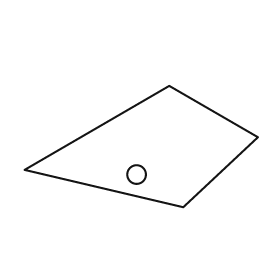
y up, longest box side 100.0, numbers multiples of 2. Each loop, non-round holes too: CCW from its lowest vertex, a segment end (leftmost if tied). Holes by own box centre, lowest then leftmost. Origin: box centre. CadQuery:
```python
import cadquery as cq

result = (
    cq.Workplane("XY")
    .moveTo(18.0, -26.0)
    .lineTo(50.0, 4.0)
    .lineTo(12.0, 26.0)
    .lineTo(-50.0, -10.0)
    .close()
    .moveTo(-2.0, -12.0)
    .circle(4.0)
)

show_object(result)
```